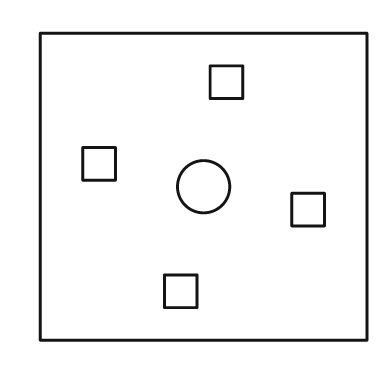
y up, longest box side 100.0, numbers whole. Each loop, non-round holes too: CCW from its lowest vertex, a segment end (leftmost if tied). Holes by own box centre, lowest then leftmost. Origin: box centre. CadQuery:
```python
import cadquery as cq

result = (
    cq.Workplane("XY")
    .moveTo(-50.0, -47.0)
    .lineTo(50.0, -47.0)
    .lineTo(50.0, 47.0)
    .lineTo(-50.0, 47.0)
    .close()
    .moveTo(-12.0, -37.0)
    .lineTo(-2.0, -37.0)
    .lineTo(-2.0, -27.0)
    .lineTo(-12.0, -27.0)
    .close()
    .moveTo(27.0, -12.0)
    .lineTo(37.0, -12.0)
    .lineTo(37.0, -2.0)
    .lineTo(27.0, -2.0)
    .close()
    .moveTo(0.0, 0.0)
    .circle(8.0)
    .moveTo(-37.0, 2.0)
    .lineTo(-27.0, 2.0)
    .lineTo(-27.0, 12.0)
    .lineTo(-37.0, 12.0)
    .close()
    .moveTo(2.0, 27.0)
    .lineTo(12.0, 27.0)
    .lineTo(12.0, 37.0)
    .lineTo(2.0, 37.0)
    .close()
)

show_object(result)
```